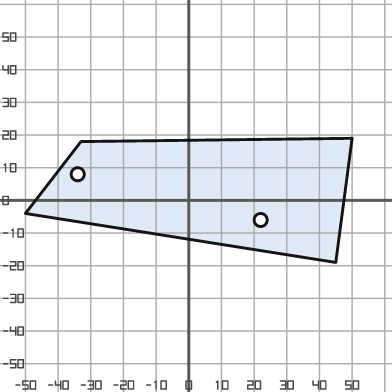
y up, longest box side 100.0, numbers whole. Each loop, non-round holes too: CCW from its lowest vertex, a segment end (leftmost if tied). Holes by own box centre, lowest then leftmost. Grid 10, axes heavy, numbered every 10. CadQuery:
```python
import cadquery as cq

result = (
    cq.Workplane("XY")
    .moveTo(45.0, -19.0)
    .lineTo(50.0, 19.0)
    .lineTo(-33.0, 18.0)
    .lineTo(-50.0, -4.0)
    .close()
    .moveTo(22.0, -6.0)
    .circle(2.0)
    .moveTo(-34.0, 8.0)
    .circle(2.0)
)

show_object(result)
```